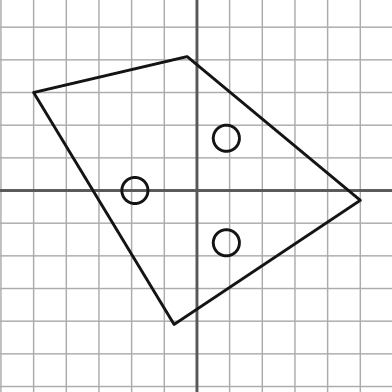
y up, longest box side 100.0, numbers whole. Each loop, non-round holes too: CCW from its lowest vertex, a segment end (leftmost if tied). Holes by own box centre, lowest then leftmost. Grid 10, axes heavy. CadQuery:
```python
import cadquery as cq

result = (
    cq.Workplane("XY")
    .moveTo(-7.0, -41.0)
    .lineTo(50.0, -3.0)
    .lineTo(-3.0, 41.0)
    .lineTo(-50.0, 30.0)
    .close()
    .moveTo(9.0, -16.0)
    .circle(4.0)
    .moveTo(-19.0, 0.0)
    .circle(4.0)
    .moveTo(9.0, 16.0)
    .circle(4.0)
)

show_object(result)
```